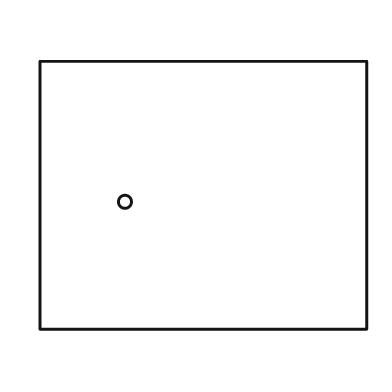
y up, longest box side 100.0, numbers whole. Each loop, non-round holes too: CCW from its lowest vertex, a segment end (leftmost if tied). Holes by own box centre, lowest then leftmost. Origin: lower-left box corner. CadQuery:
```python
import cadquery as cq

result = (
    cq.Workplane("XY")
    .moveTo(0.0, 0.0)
    .lineTo(100.0, 0.0)
    .lineTo(100.0, 82.0)
    .lineTo(0.0, 82.0)
    .close()
    .moveTo(26.0, 39.0)
    .circle(2.0)
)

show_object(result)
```